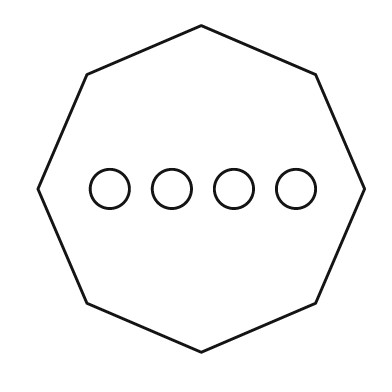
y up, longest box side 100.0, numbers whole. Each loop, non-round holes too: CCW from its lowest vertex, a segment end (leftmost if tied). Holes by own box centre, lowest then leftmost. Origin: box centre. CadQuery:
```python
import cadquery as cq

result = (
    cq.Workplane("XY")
    .moveTo(0.0, -50.0)
    .lineTo(35.0, -35.0)
    .lineTo(50.0, 0.0)
    .lineTo(35.0, 35.0)
    .lineTo(0.0, 50.0)
    .lineTo(-35.0, 35.0)
    .lineTo(-50.0, 0.0)
    .lineTo(-35.0, -35.0)
    .close()
    .moveTo(-28.0, 0.0)
    .circle(6.0)
    .moveTo(-9.0, 0.0)
    .circle(6.0)
    .moveTo(10.0, 0.0)
    .circle(6.0)
    .moveTo(29.0, 0.0)
    .circle(6.0)
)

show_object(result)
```